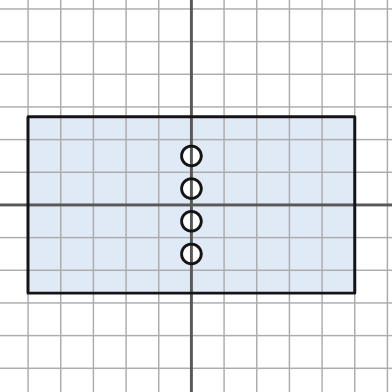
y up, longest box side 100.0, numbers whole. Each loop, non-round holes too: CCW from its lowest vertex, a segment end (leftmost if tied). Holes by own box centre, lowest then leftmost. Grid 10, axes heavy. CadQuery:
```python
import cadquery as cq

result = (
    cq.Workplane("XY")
    .moveTo(-50.0, -27.0)
    .lineTo(50.0, -27.0)
    .lineTo(50.0, 27.0)
    .lineTo(-50.0, 27.0)
    .close()
    .moveTo(0.0, -15.0)
    .circle(3.0)
    .moveTo(0.0, -5.0)
    .circle(3.0)
    .moveTo(0.0, 5.0)
    .circle(3.0)
    .moveTo(0.0, 15.0)
    .circle(3.0)
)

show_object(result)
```